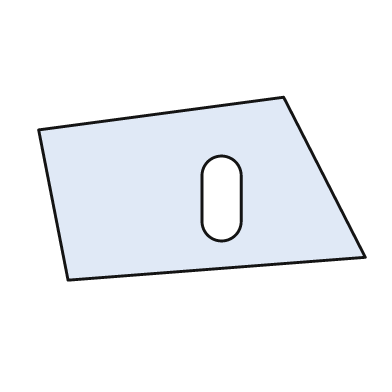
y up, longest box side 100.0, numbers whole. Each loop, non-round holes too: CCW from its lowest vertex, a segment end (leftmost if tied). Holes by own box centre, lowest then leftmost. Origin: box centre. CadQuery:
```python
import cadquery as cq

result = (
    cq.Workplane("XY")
    .moveTo(-41.0, -28.0)
    .lineTo(50.0, -21.0)
    .lineTo(25.0, 28.0)
    .lineTo(-50.0, 18.0)
    .close()
    .moveTo(0.0, -10.0)
    .threePointArc((6.0, -16.0), (12.0, -10.0))
    .lineTo(12.0, 4.0)
    .threePointArc((6.0, 10.0), (0.0, 4.0))
    .close()
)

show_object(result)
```